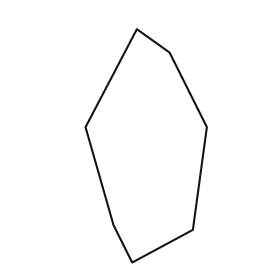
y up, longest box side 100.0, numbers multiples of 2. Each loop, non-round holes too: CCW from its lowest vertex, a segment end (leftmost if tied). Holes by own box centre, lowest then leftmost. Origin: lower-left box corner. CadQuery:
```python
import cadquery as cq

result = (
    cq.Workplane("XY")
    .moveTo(20.0, 0.0)
    .lineTo(46.0, 14.0)
    .lineTo(52.0, 58.0)
    .lineTo(36.0, 90.0)
    .lineTo(22.0, 100.0)
    .lineTo(0.0, 58.0)
    .lineTo(12.0, 16.0)
    .close()
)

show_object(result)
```